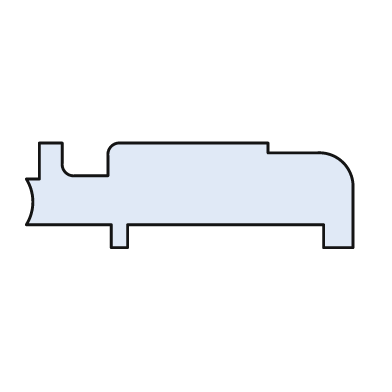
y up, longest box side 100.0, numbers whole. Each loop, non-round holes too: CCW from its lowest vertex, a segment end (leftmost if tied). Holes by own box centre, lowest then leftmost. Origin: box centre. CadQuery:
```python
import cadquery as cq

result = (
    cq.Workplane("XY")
    .moveTo(-24.0, -16.0)
    .lineTo(-19.0, -16.0)
    .lineTo(-19.0, -9.0)
    .lineTo(41.0, -9.0)
    .lineTo(41.0, -16.0)
    .lineTo(50.0, -16.0)
    .lineTo(50.0, 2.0)
    .threePointArc((47.0, 10.0), (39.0, 13.0))
    .lineTo(24.0, 13.0)
    .lineTo(24.0, 16.0)
    .lineTo(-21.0, 16.0)
    .threePointArc((-24.0, 15.0), (-25.0, 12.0))
    .lineTo(-25.0, 6.0)
    .lineTo(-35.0, 6.0)
    .threePointArc((-38.0, 7.0), (-39.0, 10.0))
    .lineTo(-39.0, 16.0)
    .lineTo(-46.0, 16.0)
    .lineTo(-46.0, 5.0)
    .lineTo(-50.0, 5.0)
    .threePointArc((-48.0, -2.0), (-50.0, -9.0))
    .lineTo(-24.0, -9.0)
    .close()
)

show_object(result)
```